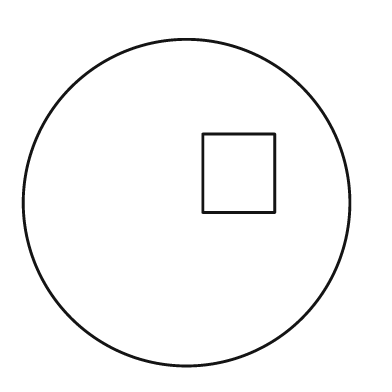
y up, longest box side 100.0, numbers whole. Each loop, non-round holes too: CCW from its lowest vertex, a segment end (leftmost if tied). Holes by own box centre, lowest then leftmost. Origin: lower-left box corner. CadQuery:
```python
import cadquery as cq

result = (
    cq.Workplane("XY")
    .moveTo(50.0, 50.0)
    .circle(50.0)
    .moveTo(55.0, 47.0)
    .lineTo(77.0, 47.0)
    .lineTo(77.0, 71.0)
    .lineTo(55.0, 71.0)
    .close()
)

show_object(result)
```